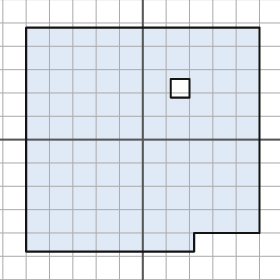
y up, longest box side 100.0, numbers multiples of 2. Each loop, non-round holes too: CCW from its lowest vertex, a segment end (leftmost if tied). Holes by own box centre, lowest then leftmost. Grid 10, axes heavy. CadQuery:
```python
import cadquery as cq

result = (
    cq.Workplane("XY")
    .moveTo(-50.0, -48.0)
    .lineTo(22.0, -48.0)
    .lineTo(22.0, -40.0)
    .lineTo(50.0, -40.0)
    .lineTo(50.0, 48.0)
    .lineTo(-50.0, 48.0)
    .close()
    .moveTo(12.0, 18.0)
    .lineTo(20.0, 18.0)
    .lineTo(20.0, 26.0)
    .lineTo(12.0, 26.0)
    .close()
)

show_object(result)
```